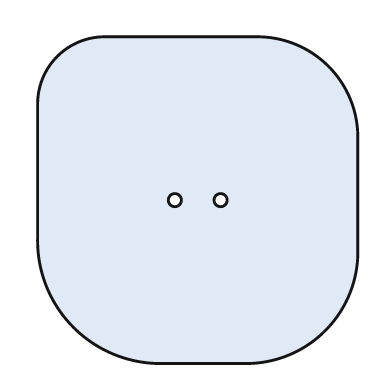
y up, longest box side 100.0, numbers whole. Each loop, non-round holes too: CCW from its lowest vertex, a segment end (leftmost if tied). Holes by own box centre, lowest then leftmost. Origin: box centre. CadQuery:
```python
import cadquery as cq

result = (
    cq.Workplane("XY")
    .moveTo(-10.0, -50.0)
    .lineTo(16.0, -50.0)
    .threePointArc((39.0, -40.0), (49.0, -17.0))
    .lineTo(49.0, 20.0)
    .threePointArc((40.0, 41.0), (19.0, 50.0))
    .lineTo(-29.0, 50.0)
    .threePointArc((-43.0, 44.0), (-49.0, 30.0))
    .lineTo(-49.0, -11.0)
    .threePointArc((-38.0, -39.0), (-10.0, -50.0))
    .close()
    .moveTo(-7.0, 0.0)
    .circle(2.0)
    .moveTo(7.0, 0.0)
    .circle(2.0)
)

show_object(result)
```